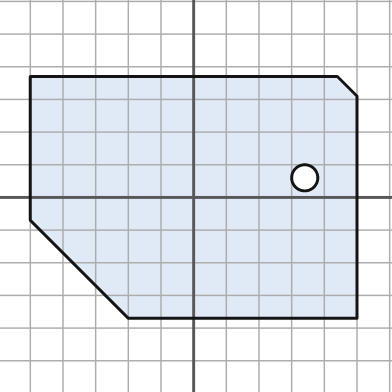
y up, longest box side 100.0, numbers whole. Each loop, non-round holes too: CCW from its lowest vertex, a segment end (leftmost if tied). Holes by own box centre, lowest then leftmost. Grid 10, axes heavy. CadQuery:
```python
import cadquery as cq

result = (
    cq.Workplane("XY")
    .moveTo(-20.0, -37.0)
    .lineTo(50.0, -37.0)
    .lineTo(50.0, 31.0)
    .lineTo(44.0, 37.0)
    .lineTo(-50.0, 37.0)
    .lineTo(-50.0, -7.0)
    .close()
    .moveTo(34.0, 6.0)
    .circle(4.0)
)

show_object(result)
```